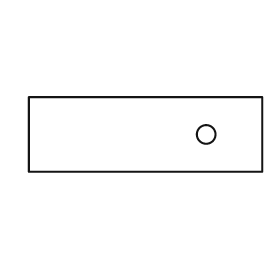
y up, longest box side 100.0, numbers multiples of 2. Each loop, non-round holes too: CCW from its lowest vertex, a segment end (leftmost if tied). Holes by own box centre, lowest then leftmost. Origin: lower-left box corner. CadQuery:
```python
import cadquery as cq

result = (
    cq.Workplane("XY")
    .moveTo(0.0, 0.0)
    .lineTo(100.0, 0.0)
    .lineTo(100.0, 32.0)
    .lineTo(0.0, 32.0)
    .close()
    .moveTo(76.0, 16.0)
    .circle(4.0)
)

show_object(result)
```